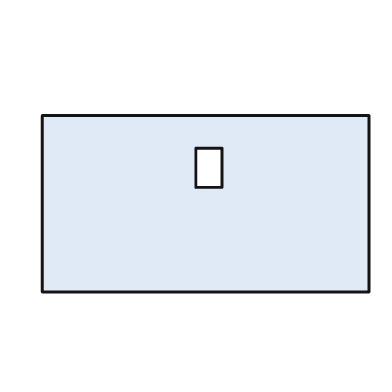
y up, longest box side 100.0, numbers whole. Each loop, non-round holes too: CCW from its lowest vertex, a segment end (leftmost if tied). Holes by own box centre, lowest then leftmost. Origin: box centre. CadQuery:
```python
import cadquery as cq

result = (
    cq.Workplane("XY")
    .moveTo(-50.0, -27.0)
    .lineTo(50.0, -27.0)
    .lineTo(50.0, 27.0)
    .lineTo(-50.0, 27.0)
    .close()
    .moveTo(-3.0, 5.0)
    .lineTo(5.0, 5.0)
    .lineTo(5.0, 17.0)
    .lineTo(-3.0, 17.0)
    .close()
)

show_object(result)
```